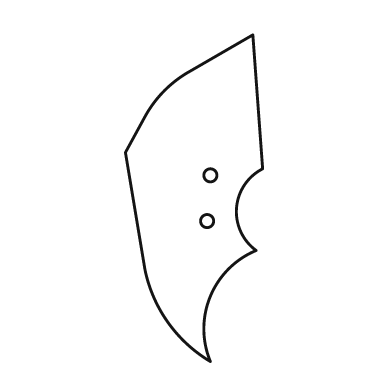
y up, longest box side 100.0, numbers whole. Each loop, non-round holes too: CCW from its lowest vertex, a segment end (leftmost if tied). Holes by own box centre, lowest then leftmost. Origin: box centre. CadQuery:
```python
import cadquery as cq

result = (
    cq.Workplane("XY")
    .moveTo(5.0, -50.0)
    .threePointArc((5.0, -30.0), (19.0, -16.0))
    .threePointArc((13.0, -3.0), (21.0, 9.0))
    .lineTo(18.0, 50.0)
    .lineTo(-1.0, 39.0)
    .threePointArc((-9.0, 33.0), (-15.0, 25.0))
    .lineTo(-21.0, 14.0)
    .lineTo(-15.0, -22.0)
    .threePointArc((-8.0, -38.0), (5.0, -50.0))
    .close()
    .moveTo(4.0, -7.0)
    .circle(2.0)
    .moveTo(5.0, 7.0)
    .circle(2.0)
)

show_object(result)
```